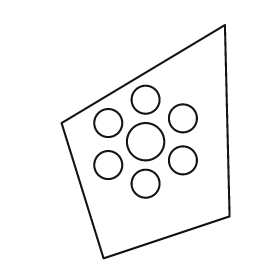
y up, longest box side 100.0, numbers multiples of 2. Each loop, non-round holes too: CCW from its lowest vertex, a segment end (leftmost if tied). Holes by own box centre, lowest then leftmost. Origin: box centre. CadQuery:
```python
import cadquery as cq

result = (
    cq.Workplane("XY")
    .moveTo(-18.0, -50.0)
    .lineTo(36.0, -32.0)
    .lineTo(34.0, 50.0)
    .lineTo(-36.0, 8.0)
    .close()
    .moveTo(0.0, -18.0)
    .circle(6.0)
    .moveTo(-16.0, -10.0)
    .circle(6.0)
    .moveTo(16.0, -8.0)
    .circle(6.0)
    .moveTo(0.0, 0.0)
    .circle(8.0)
    .moveTo(-16.0, 8.0)
    .circle(6.0)
    .moveTo(16.0, 10.0)
    .circle(6.0)
    .moveTo(0.0, 18.0)
    .circle(6.0)
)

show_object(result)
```